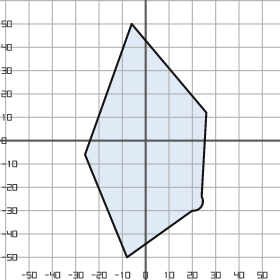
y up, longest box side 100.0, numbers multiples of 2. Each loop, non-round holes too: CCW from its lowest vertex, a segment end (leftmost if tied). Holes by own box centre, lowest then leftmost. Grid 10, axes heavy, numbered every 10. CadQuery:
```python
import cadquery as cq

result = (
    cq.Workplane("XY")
    .moveTo(-8.0, -50.0)
    .lineTo(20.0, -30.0)
    .threePointArc((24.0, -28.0), (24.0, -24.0))
    .lineTo(26.0, 12.0)
    .lineTo(-6.0, 50.0)
    .lineTo(-26.0, -6.0)
    .close()
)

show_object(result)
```